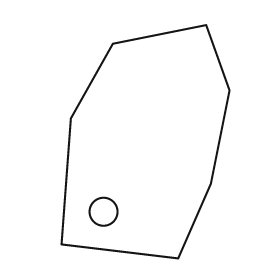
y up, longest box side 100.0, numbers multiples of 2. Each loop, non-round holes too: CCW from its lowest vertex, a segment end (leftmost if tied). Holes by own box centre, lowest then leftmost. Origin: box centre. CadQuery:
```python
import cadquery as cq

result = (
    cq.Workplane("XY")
    .moveTo(14.0, -50.0)
    .lineTo(28.0, -18.0)
    .lineTo(36.0, 22.0)
    .lineTo(26.0, 50.0)
    .lineTo(-14.0, 42.0)
    .lineTo(-32.0, 10.0)
    .lineTo(-36.0, -44.0)
    .close()
    .moveTo(-18.0, -30.0)
    .circle(6.0)
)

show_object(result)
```